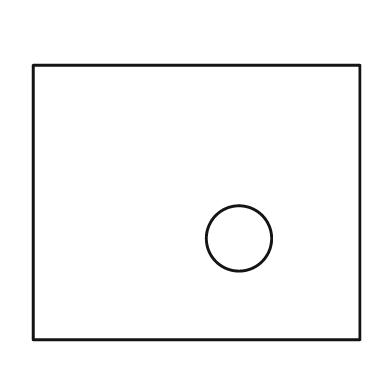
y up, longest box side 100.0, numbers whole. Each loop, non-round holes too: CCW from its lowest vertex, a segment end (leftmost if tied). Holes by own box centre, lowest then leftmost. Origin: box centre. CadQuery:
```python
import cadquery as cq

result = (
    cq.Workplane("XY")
    .moveTo(-50.0, -42.0)
    .lineTo(50.0, -42.0)
    .lineTo(50.0, 42.0)
    .lineTo(-50.0, 42.0)
    .close()
    .moveTo(13.0, -11.0)
    .circle(10.0)
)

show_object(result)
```